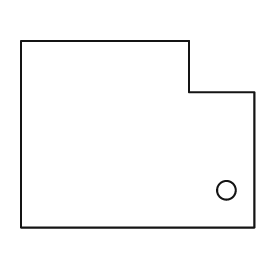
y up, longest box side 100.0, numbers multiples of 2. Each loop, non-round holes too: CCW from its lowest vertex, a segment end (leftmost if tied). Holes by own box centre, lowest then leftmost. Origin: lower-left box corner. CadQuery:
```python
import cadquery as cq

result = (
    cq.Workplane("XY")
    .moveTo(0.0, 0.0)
    .lineTo(100.0, 0.0)
    .lineTo(100.0, 58.0)
    .lineTo(72.0, 58.0)
    .lineTo(72.0, 80.0)
    .lineTo(0.0, 80.0)
    .close()
    .moveTo(88.0, 16.0)
    .circle(4.0)
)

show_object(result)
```